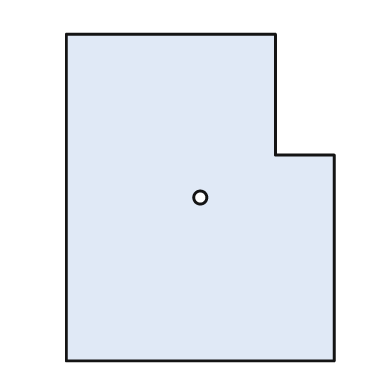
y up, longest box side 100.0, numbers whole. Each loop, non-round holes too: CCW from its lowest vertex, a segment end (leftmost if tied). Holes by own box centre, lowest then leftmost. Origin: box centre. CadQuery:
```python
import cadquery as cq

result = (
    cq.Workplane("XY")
    .moveTo(-41.0, -50.0)
    .lineTo(41.0, -50.0)
    .lineTo(41.0, 13.0)
    .lineTo(23.0, 13.0)
    .lineTo(23.0, 50.0)
    .lineTo(-41.0, 50.0)
    .close()
    .moveTo(0.0, 0.0)
    .circle(2.0)
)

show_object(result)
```